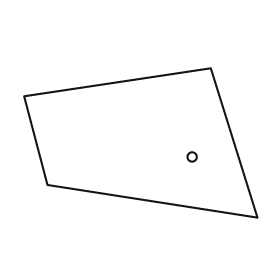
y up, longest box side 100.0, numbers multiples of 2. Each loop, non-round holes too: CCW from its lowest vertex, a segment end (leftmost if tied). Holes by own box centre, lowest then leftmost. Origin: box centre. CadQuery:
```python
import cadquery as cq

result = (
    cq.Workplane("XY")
    .moveTo(50.0, -32.0)
    .lineTo(30.0, 32.0)
    .lineTo(-50.0, 20.0)
    .lineTo(-40.0, -18.0)
    .close()
    .moveTo(22.0, -6.0)
    .circle(2.0)
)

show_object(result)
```